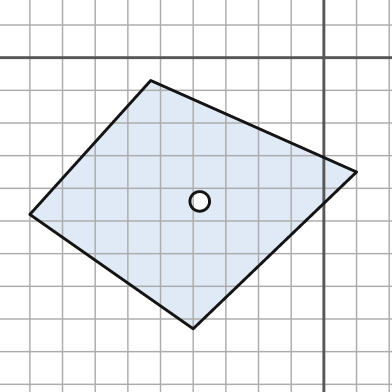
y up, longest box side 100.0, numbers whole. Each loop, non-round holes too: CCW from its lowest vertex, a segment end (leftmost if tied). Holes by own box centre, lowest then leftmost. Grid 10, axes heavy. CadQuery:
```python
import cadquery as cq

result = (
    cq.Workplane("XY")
    .moveTo(-40.0, -83.0)
    .lineTo(10.0, -35.0)
    .lineTo(-53.0, -7.0)
    .lineTo(-90.0, -48.0)
    .close()
    .moveTo(-38.0, -44.0)
    .circle(3.0)
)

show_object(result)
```